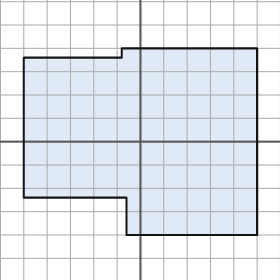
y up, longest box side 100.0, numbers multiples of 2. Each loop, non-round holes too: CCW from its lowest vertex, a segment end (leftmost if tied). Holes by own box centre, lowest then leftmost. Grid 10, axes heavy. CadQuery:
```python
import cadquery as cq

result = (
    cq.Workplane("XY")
    .moveTo(-6.0, -40.0)
    .lineTo(50.0, -40.0)
    .lineTo(50.0, 40.0)
    .lineTo(-8.0, 40.0)
    .lineTo(-8.0, 36.0)
    .lineTo(-50.0, 36.0)
    .lineTo(-50.0, -24.0)
    .lineTo(-6.0, -24.0)
    .close()
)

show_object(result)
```